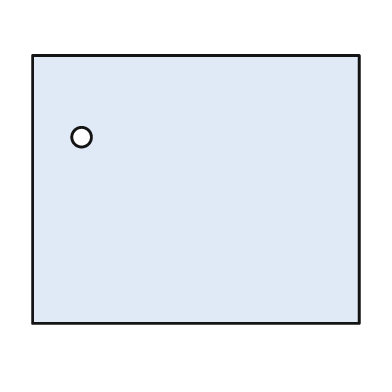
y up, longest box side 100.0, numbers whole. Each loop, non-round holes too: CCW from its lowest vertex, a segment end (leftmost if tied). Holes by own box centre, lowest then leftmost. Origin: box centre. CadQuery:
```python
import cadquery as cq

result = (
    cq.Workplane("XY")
    .moveTo(-50.0, -41.0)
    .lineTo(50.0, -41.0)
    .lineTo(50.0, 41.0)
    .lineTo(-50.0, 41.0)
    .close()
    .moveTo(-35.0, 16.0)
    .circle(3.0)
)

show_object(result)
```